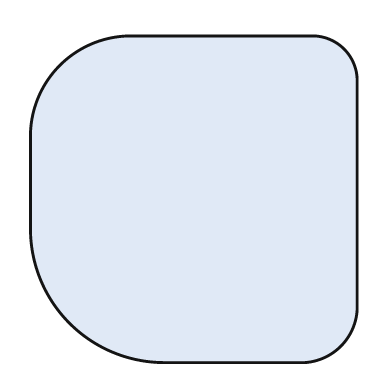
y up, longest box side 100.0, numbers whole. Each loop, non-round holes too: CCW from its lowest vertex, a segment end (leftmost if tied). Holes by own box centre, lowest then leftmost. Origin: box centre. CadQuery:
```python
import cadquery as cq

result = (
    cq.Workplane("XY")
    .moveTo(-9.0, -50.0)
    .lineTo(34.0, -50.0)
    .threePointArc((45.0, -45.0), (50.0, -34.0))
    .lineTo(50.0, 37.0)
    .threePointArc((46.0, 46.0), (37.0, 50.0))
    .lineTo(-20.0, 50.0)
    .threePointArc((-41.0, 41.0), (-50.0, 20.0))
    .lineTo(-50.0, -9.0)
    .threePointArc((-38.0, -38.0), (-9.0, -50.0))
    .close()
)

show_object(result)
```